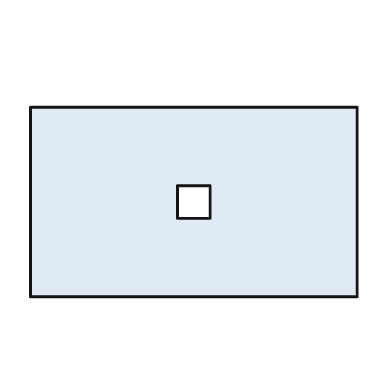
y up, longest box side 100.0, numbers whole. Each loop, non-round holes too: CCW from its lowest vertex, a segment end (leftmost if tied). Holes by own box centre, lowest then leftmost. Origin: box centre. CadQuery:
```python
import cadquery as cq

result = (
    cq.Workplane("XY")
    .moveTo(-50.0, -29.0)
    .lineTo(50.0, -29.0)
    .lineTo(50.0, 29.0)
    .lineTo(-50.0, 29.0)
    .close()
    .moveTo(-5.0, -5.0)
    .lineTo(5.0, -5.0)
    .lineTo(5.0, 5.0)
    .lineTo(-5.0, 5.0)
    .close()
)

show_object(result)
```